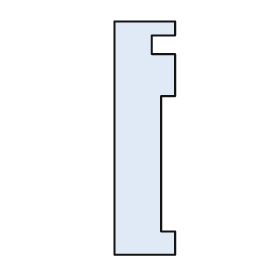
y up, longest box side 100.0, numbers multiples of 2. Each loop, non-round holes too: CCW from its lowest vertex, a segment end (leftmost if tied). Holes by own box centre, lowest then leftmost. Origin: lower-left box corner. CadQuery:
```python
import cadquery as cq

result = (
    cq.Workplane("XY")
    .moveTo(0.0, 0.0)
    .lineTo(26.0, 0.0)
    .lineTo(26.0, 10.0)
    .lineTo(20.0, 10.0)
    .lineTo(20.0, 68.0)
    .lineTo(26.0, 68.0)
    .lineTo(26.0, 86.0)
    .lineTo(16.0, 86.0)
    .lineTo(16.0, 94.0)
    .lineTo(26.0, 94.0)
    .lineTo(26.0, 100.0)
    .lineTo(0.0, 100.0)
    .close()
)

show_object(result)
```